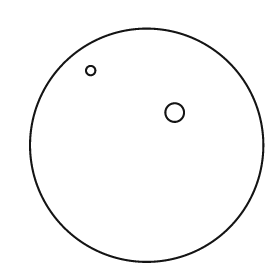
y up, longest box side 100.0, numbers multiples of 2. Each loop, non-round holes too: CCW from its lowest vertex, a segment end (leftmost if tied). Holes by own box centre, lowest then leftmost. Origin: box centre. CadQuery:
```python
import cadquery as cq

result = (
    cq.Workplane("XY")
    .moveTo(0.0, 0.0)
    .circle(50.0)
    .moveTo(12.0, 14.0)
    .circle(4.0)
    .moveTo(-24.0, 32.0)
    .circle(2.0)
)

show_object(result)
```